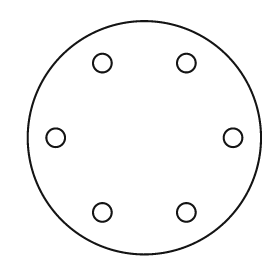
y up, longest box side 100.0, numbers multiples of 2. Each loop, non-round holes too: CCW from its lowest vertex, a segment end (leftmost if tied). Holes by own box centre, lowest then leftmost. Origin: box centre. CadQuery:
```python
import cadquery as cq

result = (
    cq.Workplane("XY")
    .moveTo(0.0, 0.0)
    .circle(50.0)
    .moveTo(-18.0, -32.0)
    .circle(4.0)
    .moveTo(18.0, -32.0)
    .circle(4.0)
    .moveTo(-38.0, 0.0)
    .circle(4.0)
    .moveTo(38.0, 0.0)
    .circle(4.0)
    .moveTo(-18.0, 32.0)
    .circle(4.0)
    .moveTo(18.0, 32.0)
    .circle(4.0)
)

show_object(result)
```